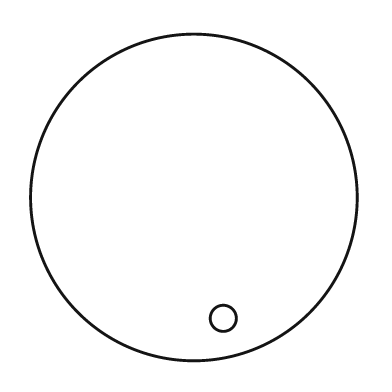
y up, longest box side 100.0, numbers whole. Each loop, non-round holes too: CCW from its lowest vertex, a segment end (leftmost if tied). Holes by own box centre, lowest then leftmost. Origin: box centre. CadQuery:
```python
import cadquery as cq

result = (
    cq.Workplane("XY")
    .moveTo(0.0, 0.0)
    .circle(50.0)
    .moveTo(9.0, -37.0)
    .circle(4.0)
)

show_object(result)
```